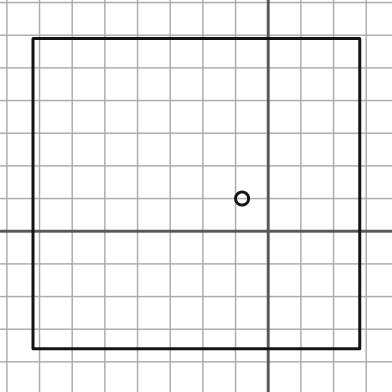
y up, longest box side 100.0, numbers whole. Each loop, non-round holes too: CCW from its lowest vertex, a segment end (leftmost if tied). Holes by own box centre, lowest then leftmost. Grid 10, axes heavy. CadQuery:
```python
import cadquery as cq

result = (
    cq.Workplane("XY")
    .moveTo(-72.0, -36.0)
    .lineTo(28.0, -36.0)
    .lineTo(28.0, 59.0)
    .lineTo(-72.0, 59.0)
    .close()
    .moveTo(-8.0, 10.0)
    .circle(2.0)
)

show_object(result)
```